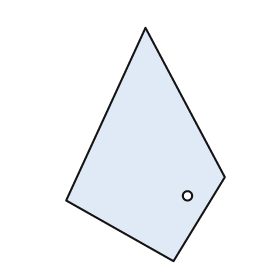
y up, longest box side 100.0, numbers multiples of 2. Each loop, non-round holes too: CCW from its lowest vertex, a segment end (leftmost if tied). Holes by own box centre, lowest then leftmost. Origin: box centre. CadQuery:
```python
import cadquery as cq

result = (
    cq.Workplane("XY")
    .moveTo(12.0, -50.0)
    .lineTo(34.0, -14.0)
    .lineTo(0.0, 50.0)
    .lineTo(-34.0, -24.0)
    .close()
    .moveTo(18.0, -22.0)
    .circle(2.0)
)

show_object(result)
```